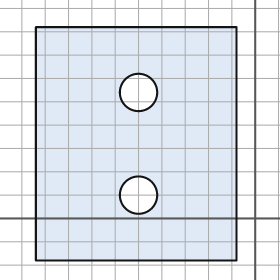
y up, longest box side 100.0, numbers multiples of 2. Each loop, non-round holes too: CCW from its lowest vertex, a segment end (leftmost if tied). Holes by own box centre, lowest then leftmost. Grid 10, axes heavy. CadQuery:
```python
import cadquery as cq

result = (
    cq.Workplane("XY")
    .moveTo(-94.0, -18.0)
    .lineTo(-8.0, -18.0)
    .lineTo(-8.0, 82.0)
    .lineTo(-94.0, 82.0)
    .close()
    .moveTo(-50.0, 10.0)
    .circle(8.0)
    .moveTo(-50.0, 54.0)
    .circle(8.0)
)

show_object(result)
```